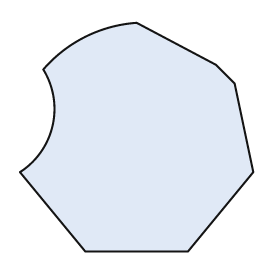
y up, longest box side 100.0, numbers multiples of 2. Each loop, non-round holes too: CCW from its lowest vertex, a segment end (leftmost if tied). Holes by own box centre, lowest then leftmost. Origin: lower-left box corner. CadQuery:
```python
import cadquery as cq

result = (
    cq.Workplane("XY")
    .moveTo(28.0, 0.0)
    .lineTo(72.0, 0.0)
    .lineTo(100.0, 34.0)
    .lineTo(92.0, 72.0)
    .lineTo(84.0, 80.0)
    .lineTo(50.0, 98.0)
    .threePointArc((28.0, 92.0), (10.0, 78.0))
    .threePointArc((14.0, 54.0), (0.0, 34.0))
    .close()
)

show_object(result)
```